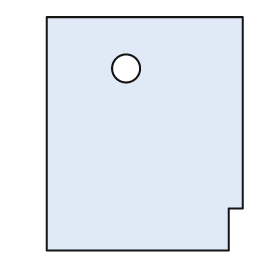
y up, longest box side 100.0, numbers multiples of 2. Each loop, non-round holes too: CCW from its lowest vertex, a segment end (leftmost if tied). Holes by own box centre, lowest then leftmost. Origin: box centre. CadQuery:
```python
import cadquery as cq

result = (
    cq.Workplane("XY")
    .moveTo(-42.0, -50.0)
    .lineTo(36.0, -50.0)
    .lineTo(36.0, -32.0)
    .lineTo(42.0, -32.0)
    .lineTo(42.0, 50.0)
    .lineTo(-42.0, 50.0)
    .close()
    .moveTo(-8.0, 28.0)
    .circle(6.0)
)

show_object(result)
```